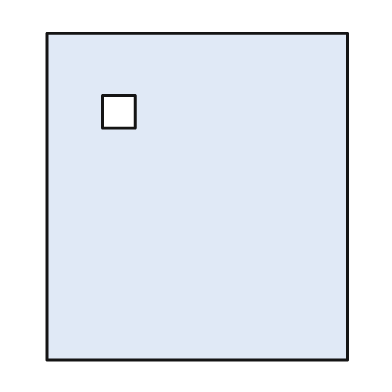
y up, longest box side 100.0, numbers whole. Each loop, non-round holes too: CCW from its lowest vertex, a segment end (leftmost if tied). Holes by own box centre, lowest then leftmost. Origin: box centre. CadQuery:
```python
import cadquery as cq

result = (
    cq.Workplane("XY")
    .moveTo(-46.0, -50.0)
    .lineTo(46.0, -50.0)
    .lineTo(46.0, 50.0)
    .lineTo(-46.0, 50.0)
    .close()
    .moveTo(-29.0, 21.0)
    .lineTo(-19.0, 21.0)
    .lineTo(-19.0, 31.0)
    .lineTo(-29.0, 31.0)
    .close()
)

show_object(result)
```